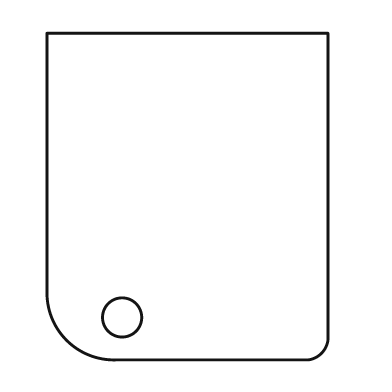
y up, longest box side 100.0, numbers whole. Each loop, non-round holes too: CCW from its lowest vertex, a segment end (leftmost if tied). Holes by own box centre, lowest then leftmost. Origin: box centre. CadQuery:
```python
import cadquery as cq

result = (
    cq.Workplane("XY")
    .moveTo(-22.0, -50.0)
    .lineTo(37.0, -50.0)
    .threePointArc((41.0, -48.0), (43.0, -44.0))
    .lineTo(43.0, 50.0)
    .lineTo(-43.0, 50.0)
    .lineTo(-43.0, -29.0)
    .threePointArc((-37.0, -44.0), (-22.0, -50.0))
    .close()
    .moveTo(-20.0, -37.0)
    .circle(6.0)
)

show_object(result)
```